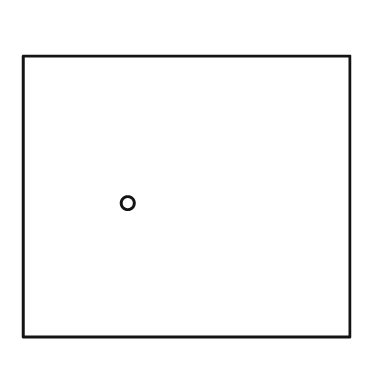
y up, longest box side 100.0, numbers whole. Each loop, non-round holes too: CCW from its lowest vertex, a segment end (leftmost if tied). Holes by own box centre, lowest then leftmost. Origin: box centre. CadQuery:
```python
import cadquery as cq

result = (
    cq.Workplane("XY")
    .moveTo(-50.0, -43.0)
    .lineTo(50.0, -43.0)
    .lineTo(50.0, 43.0)
    .lineTo(-50.0, 43.0)
    .close()
    .moveTo(-18.0, -2.0)
    .circle(2.0)
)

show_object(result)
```